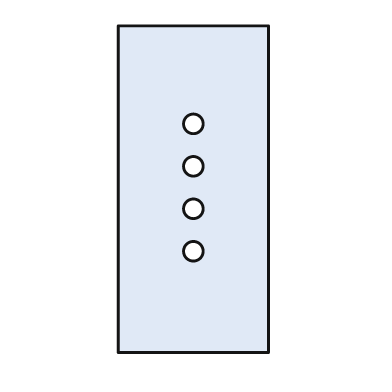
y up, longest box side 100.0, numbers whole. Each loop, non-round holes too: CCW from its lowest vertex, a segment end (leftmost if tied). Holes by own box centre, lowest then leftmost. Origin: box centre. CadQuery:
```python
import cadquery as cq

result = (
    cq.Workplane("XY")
    .moveTo(-23.0, -50.0)
    .lineTo(23.0, -50.0)
    .lineTo(23.0, 50.0)
    .lineTo(-23.0, 50.0)
    .close()
    .moveTo(0.0, -19.0)
    .circle(3.0)
    .moveTo(0.0, -6.0)
    .circle(3.0)
    .moveTo(0.0, 7.0)
    .circle(3.0)
    .moveTo(0.0, 20.0)
    .circle(3.0)
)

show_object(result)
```